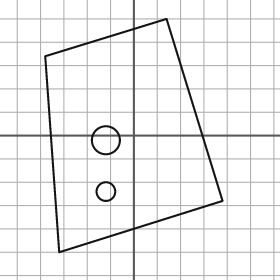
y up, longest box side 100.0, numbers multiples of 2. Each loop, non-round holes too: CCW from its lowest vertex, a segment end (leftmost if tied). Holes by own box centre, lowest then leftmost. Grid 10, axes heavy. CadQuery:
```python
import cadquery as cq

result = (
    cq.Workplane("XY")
    .moveTo(-32.0, -50.0)
    .lineTo(38.0, -28.0)
    .lineTo(14.0, 50.0)
    .lineTo(-38.0, 34.0)
    .close()
    .moveTo(-12.0, -24.0)
    .circle(4.0)
    .moveTo(-12.0, -2.0)
    .circle(6.0)
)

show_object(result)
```